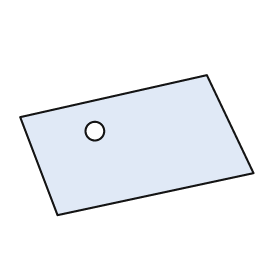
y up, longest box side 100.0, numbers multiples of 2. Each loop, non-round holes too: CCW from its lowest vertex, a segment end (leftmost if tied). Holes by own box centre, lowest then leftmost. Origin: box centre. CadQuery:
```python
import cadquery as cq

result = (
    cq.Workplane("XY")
    .moveTo(-34.0, -30.0)
    .lineTo(50.0, -12.0)
    .lineTo(30.0, 30.0)
    .lineTo(-50.0, 12.0)
    .close()
    .moveTo(-18.0, 6.0)
    .circle(4.0)
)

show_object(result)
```